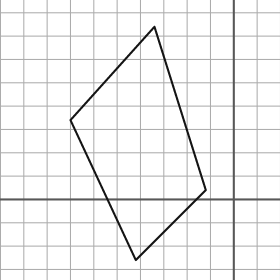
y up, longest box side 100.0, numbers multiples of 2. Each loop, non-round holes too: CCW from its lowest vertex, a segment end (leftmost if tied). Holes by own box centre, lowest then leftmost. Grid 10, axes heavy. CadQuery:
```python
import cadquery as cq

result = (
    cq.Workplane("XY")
    .moveTo(-42.0, -26.0)
    .lineTo(-12.0, 4.0)
    .lineTo(-34.0, 74.0)
    .lineTo(-70.0, 34.0)
    .close()
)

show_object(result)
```